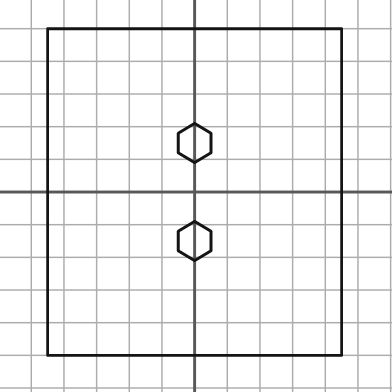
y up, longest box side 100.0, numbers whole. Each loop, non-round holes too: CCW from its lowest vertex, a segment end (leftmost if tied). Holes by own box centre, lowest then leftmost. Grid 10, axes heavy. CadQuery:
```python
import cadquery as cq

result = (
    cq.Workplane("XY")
    .moveTo(-45.0, -50.0)
    .lineTo(45.0, -50.0)
    .lineTo(45.0, 50.0)
    .lineTo(-45.0, 50.0)
    .close()
    .moveTo(0.0, -21.0)
    .lineTo(5.0, -18.0)
    .lineTo(5.0, -12.0)
    .lineTo(0.0, -9.0)
    .lineTo(-5.0, -12.0)
    .lineTo(-5.0, -18.0)
    .close()
    .moveTo(0.0, 9.0)
    .lineTo(5.0, 12.0)
    .lineTo(5.0, 18.0)
    .lineTo(0.0, 21.0)
    .lineTo(-5.0, 18.0)
    .lineTo(-5.0, 12.0)
    .close()
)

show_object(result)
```